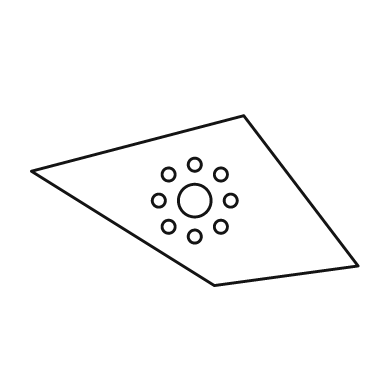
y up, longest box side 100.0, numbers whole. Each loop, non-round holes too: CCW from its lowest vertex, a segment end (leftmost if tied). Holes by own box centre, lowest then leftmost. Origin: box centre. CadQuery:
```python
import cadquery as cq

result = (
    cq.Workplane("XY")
    .moveTo(6.0, -26.0)
    .lineTo(50.0, -20.0)
    .lineTo(15.0, 26.0)
    .lineTo(-50.0, 9.0)
    .close()
    .moveTo(0.0, -11.0)
    .circle(2.0)
    .moveTo(-8.0, -8.0)
    .circle(2.0)
    .moveTo(8.0, -8.0)
    .circle(2.0)
    .moveTo(-11.0, 0.0)
    .circle(2.0)
    .moveTo(0.0, 0.0)
    .circle(5.0)
    .moveTo(11.0, 0.0)
    .circle(2.0)
    .moveTo(-8.0, 8.0)
    .circle(2.0)
    .moveTo(8.0, 8.0)
    .circle(2.0)
    .moveTo(0.0, 11.0)
    .circle(2.0)
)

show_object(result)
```